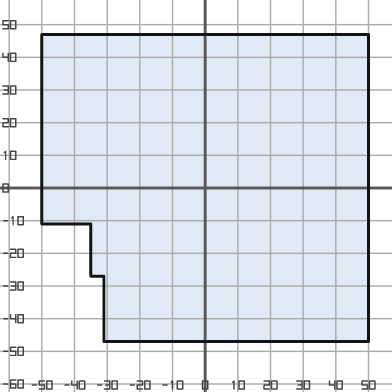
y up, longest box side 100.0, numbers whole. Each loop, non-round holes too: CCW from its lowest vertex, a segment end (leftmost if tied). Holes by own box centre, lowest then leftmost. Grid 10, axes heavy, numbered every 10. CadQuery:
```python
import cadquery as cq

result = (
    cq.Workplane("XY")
    .moveTo(-31.0, -47.0)
    .lineTo(50.0, -47.0)
    .lineTo(50.0, 47.0)
    .lineTo(-50.0, 47.0)
    .lineTo(-50.0, -11.0)
    .lineTo(-35.0, -11.0)
    .lineTo(-35.0, -27.0)
    .lineTo(-31.0, -27.0)
    .close()
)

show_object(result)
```